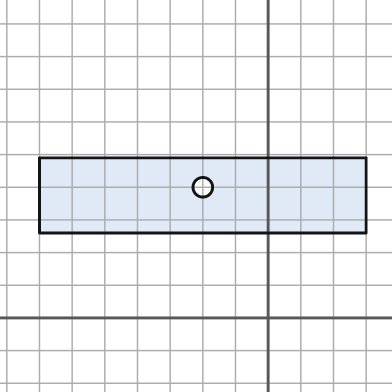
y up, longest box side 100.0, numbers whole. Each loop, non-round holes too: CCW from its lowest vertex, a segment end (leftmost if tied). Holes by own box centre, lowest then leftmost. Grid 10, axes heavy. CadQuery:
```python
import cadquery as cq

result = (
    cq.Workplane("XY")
    .moveTo(-70.0, 26.0)
    .lineTo(30.0, 26.0)
    .lineTo(30.0, 49.0)
    .lineTo(-70.0, 49.0)
    .close()
    .moveTo(-20.0, 40.0)
    .circle(3.0)
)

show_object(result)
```